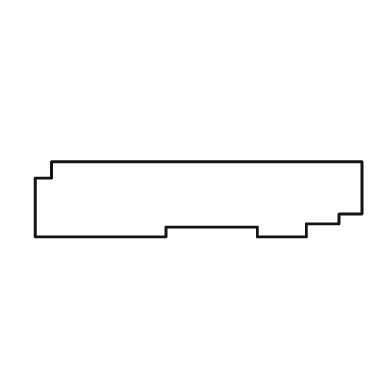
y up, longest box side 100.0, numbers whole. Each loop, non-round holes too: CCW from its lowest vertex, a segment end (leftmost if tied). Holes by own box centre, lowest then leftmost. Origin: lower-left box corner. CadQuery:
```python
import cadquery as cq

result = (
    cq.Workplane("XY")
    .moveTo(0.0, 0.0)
    .lineTo(40.0, 0.0)
    .lineTo(40.0, 3.0)
    .lineTo(68.0, 3.0)
    .lineTo(68.0, 0.0)
    .lineTo(83.0, 0.0)
    .lineTo(83.0, 4.0)
    .lineTo(93.0, 4.0)
    .lineTo(93.0, 7.0)
    .lineTo(100.0, 7.0)
    .lineTo(100.0, 23.0)
    .lineTo(5.0, 23.0)
    .lineTo(5.0, 18.0)
    .lineTo(0.0, 18.0)
    .close()
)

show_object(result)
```